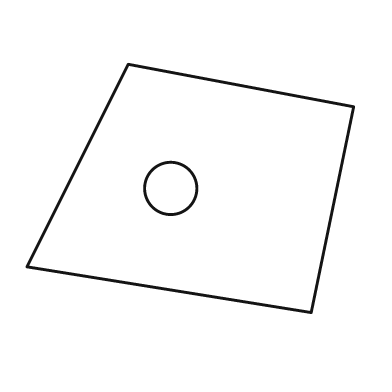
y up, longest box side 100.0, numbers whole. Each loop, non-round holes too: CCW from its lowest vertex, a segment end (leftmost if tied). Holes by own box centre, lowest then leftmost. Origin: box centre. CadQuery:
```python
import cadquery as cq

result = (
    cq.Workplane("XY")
    .moveTo(37.0, -38.0)
    .lineTo(50.0, 25.0)
    .lineTo(-19.0, 38.0)
    .lineTo(-50.0, -24.0)
    .close()
    .moveTo(-6.0, 0.0)
    .circle(8.0)
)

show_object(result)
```